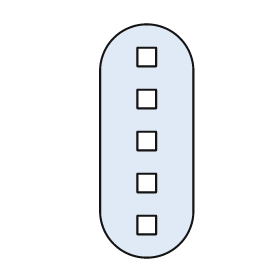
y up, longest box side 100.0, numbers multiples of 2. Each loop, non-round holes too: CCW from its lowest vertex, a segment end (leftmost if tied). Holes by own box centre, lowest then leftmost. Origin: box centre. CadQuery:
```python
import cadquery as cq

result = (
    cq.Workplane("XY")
    .moveTo(-20.0, -30.0)
    .threePointArc((0.0, -50.0), (20.0, -30.0))
    .lineTo(20.0, 30.0)
    .threePointArc((0.0, 50.0), (-20.0, 30.0))
    .close()
    .moveTo(-4.0, -40.0)
    .lineTo(4.0, -40.0)
    .lineTo(4.0, -32.0)
    .lineTo(-4.0, -32.0)
    .close()
    .moveTo(-4.0, -22.0)
    .lineTo(4.0, -22.0)
    .lineTo(4.0, -14.0)
    .lineTo(-4.0, -14.0)
    .close()
    .moveTo(-4.0, -4.0)
    .lineTo(4.0, -4.0)
    .lineTo(4.0, 4.0)
    .lineTo(-4.0, 4.0)
    .close()
    .moveTo(-4.0, 14.0)
    .lineTo(4.0, 14.0)
    .lineTo(4.0, 22.0)
    .lineTo(-4.0, 22.0)
    .close()
    .moveTo(-4.0, 32.0)
    .lineTo(4.0, 32.0)
    .lineTo(4.0, 40.0)
    .lineTo(-4.0, 40.0)
    .close()
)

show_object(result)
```